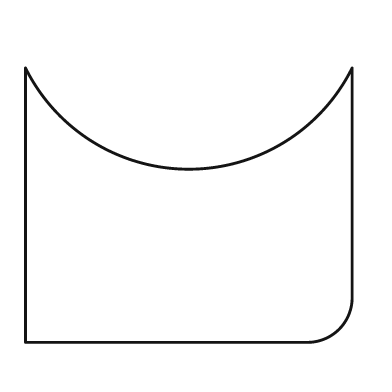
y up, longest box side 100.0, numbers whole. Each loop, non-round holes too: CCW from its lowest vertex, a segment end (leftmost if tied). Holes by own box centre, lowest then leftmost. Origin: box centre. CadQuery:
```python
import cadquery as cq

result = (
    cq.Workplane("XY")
    .moveTo(-50.0, -42.0)
    .lineTo(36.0, -42.0)
    .threePointArc((46.0, -38.0), (50.0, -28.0))
    .lineTo(50.0, 42.0)
    .threePointArc((0.0, 11.0), (-50.0, 42.0))
    .close()
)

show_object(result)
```